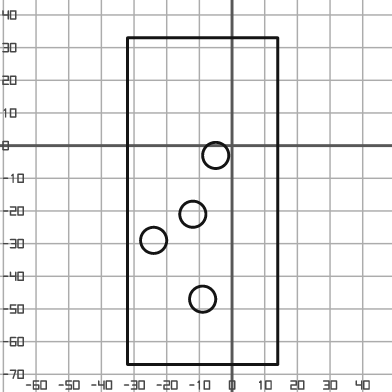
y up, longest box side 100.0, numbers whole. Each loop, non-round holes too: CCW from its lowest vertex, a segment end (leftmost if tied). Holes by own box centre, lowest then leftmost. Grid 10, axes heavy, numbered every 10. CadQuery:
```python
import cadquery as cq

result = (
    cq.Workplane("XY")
    .moveTo(-32.0, -67.0)
    .lineTo(14.0, -67.0)
    .lineTo(14.0, 33.0)
    .lineTo(-32.0, 33.0)
    .close()
    .moveTo(-9.0, -47.0)
    .circle(4.0)
    .moveTo(-24.0, -29.0)
    .circle(4.0)
    .moveTo(-12.0, -21.0)
    .circle(4.0)
    .moveTo(-5.0, -3.0)
    .circle(4.0)
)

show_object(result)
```